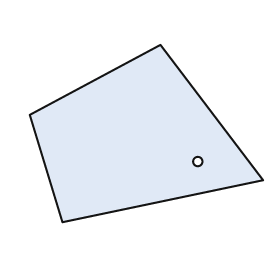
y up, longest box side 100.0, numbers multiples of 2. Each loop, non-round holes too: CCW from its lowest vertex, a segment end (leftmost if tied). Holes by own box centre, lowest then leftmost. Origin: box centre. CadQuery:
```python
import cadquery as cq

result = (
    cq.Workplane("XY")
    .moveTo(-36.0, -38.0)
    .lineTo(50.0, -20.0)
    .lineTo(6.0, 38.0)
    .lineTo(-50.0, 8.0)
    .close()
    .moveTo(22.0, -12.0)
    .circle(2.0)
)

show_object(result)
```